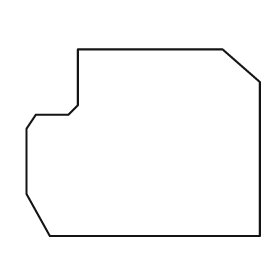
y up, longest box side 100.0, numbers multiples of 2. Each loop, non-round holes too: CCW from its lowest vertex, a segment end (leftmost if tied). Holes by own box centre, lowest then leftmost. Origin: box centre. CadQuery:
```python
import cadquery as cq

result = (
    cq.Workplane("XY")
    .moveTo(-40.0, -40.0)
    .lineTo(50.0, -40.0)
    .lineTo(50.0, 26.0)
    .lineTo(34.0, 40.0)
    .lineTo(-28.0, 40.0)
    .lineTo(-28.0, 16.0)
    .lineTo(-32.0, 12.0)
    .lineTo(-46.0, 12.0)
    .lineTo(-50.0, 6.0)
    .lineTo(-50.0, -22.0)
    .close()
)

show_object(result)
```